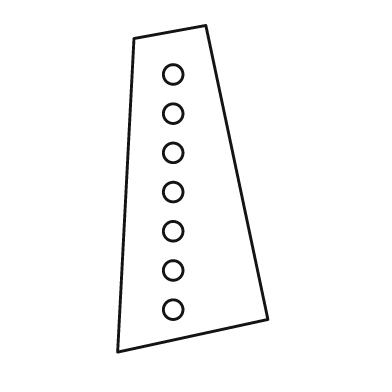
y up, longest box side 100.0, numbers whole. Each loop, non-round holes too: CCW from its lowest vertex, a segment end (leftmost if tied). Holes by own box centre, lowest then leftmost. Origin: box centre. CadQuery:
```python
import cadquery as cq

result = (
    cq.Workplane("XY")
    .moveTo(-23.0, -50.0)
    .lineTo(23.0, -40.0)
    .lineTo(4.0, 50.0)
    .lineTo(-18.0, 46.0)
    .close()
    .moveTo(-6.0, -37.0)
    .circle(3.0)
    .moveTo(-6.0, -25.0)
    .circle(3.0)
    .moveTo(-6.0, -13.0)
    .circle(3.0)
    .moveTo(-6.0, -1.0)
    .circle(3.0)
    .moveTo(-6.0, 11.0)
    .circle(3.0)
    .moveTo(-6.0, 23.0)
    .circle(3.0)
    .moveTo(-6.0, 35.0)
    .circle(3.0)
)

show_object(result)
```